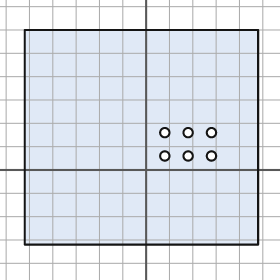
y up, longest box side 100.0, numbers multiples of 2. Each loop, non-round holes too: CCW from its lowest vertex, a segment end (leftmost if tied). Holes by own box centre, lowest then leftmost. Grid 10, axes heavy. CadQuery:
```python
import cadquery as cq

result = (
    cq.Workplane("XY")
    .moveTo(-52.0, -32.0)
    .lineTo(48.0, -32.0)
    .lineTo(48.0, 60.0)
    .lineTo(-52.0, 60.0)
    .close()
    .moveTo(8.0, 6.0)
    .circle(2.0)
    .moveTo(18.0, 6.0)
    .circle(2.0)
    .moveTo(28.0, 6.0)
    .circle(2.0)
    .moveTo(8.0, 16.0)
    .circle(2.0)
    .moveTo(18.0, 16.0)
    .circle(2.0)
    .moveTo(28.0, 16.0)
    .circle(2.0)
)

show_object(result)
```